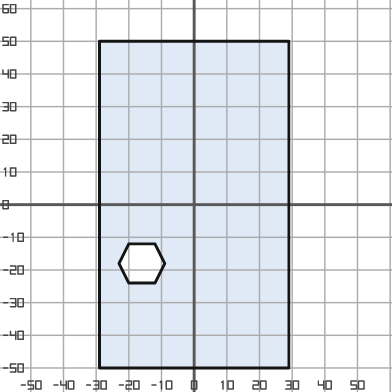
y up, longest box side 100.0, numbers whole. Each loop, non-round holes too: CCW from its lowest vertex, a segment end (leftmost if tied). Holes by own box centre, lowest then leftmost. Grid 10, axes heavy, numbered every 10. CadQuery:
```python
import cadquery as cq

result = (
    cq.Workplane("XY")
    .moveTo(-29.0, -50.0)
    .lineTo(29.0, -50.0)
    .lineTo(29.0, 50.0)
    .lineTo(-29.0, 50.0)
    .close()
    .moveTo(-20.0, -24.0)
    .lineTo(-12.0, -24.0)
    .lineTo(-9.0, -18.0)
    .lineTo(-12.0, -12.0)
    .lineTo(-20.0, -12.0)
    .lineTo(-23.0, -18.0)
    .close()
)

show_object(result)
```